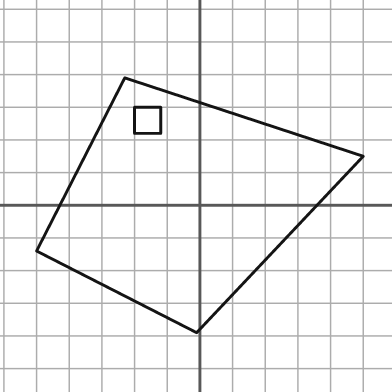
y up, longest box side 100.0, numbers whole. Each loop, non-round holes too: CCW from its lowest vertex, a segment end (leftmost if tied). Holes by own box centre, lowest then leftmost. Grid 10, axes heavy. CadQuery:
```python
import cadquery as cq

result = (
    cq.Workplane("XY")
    .moveTo(-1.0, -39.0)
    .lineTo(50.0, 15.0)
    .lineTo(-23.0, 39.0)
    .lineTo(-50.0, -14.0)
    .close()
    .moveTo(-20.0, 22.0)
    .lineTo(-12.0, 22.0)
    .lineTo(-12.0, 30.0)
    .lineTo(-20.0, 30.0)
    .close()
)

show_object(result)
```